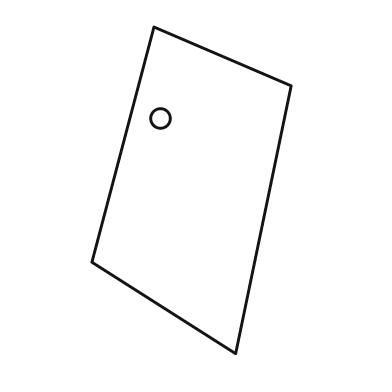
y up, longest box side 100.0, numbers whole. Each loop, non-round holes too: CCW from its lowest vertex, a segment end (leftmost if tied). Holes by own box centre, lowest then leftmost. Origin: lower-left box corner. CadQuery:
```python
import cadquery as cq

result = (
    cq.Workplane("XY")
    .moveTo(44.0, 0.0)
    .lineTo(61.0, 82.0)
    .lineTo(19.0, 100.0)
    .lineTo(0.0, 28.0)
    .close()
    .moveTo(21.0, 72.0)
    .circle(3.0)
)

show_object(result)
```